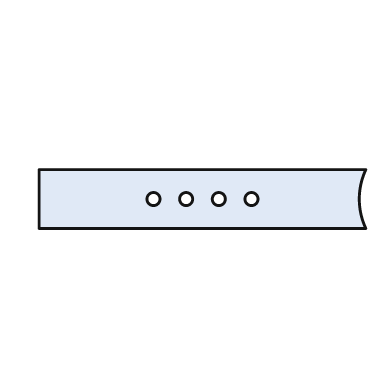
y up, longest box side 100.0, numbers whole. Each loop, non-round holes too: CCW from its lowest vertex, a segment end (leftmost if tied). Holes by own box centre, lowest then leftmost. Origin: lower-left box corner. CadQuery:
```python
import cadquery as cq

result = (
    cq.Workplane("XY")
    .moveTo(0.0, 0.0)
    .lineTo(100.0, 0.0)
    .threePointArc((98.0, 9.0), (100.0, 18.0))
    .lineTo(0.0, 18.0)
    .close()
    .moveTo(35.0, 9.0)
    .circle(2.0)
    .moveTo(45.0, 9.0)
    .circle(2.0)
    .moveTo(55.0, 9.0)
    .circle(2.0)
    .moveTo(65.0, 9.0)
    .circle(2.0)
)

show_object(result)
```